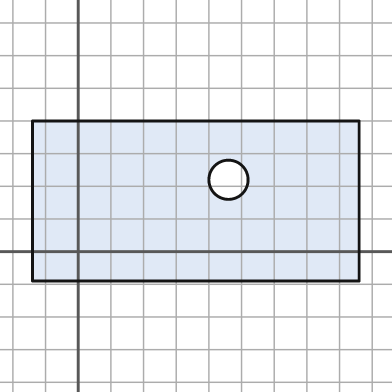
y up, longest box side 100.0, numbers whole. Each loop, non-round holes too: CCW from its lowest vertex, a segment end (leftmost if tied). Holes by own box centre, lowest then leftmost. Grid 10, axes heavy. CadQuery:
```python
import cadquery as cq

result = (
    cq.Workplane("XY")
    .moveTo(-14.0, -9.0)
    .lineTo(86.0, -9.0)
    .lineTo(86.0, 40.0)
    .lineTo(-14.0, 40.0)
    .close()
    .moveTo(46.0, 22.0)
    .circle(6.0)
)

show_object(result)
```